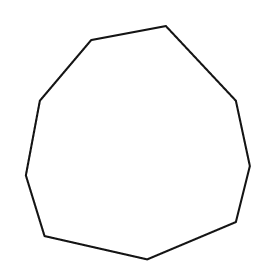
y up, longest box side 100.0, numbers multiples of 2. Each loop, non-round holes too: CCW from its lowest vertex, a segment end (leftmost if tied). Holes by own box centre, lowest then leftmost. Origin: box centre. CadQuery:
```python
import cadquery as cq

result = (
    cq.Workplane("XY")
    .moveTo(4.0, -50.0)
    .lineTo(42.0, -34.0)
    .lineTo(48.0, -10.0)
    .lineTo(42.0, 18.0)
    .lineTo(12.0, 50.0)
    .lineTo(-20.0, 44.0)
    .lineTo(-42.0, 18.0)
    .lineTo(-48.0, -14.0)
    .lineTo(-40.0, -40.0)
    .close()
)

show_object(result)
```